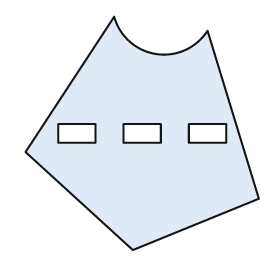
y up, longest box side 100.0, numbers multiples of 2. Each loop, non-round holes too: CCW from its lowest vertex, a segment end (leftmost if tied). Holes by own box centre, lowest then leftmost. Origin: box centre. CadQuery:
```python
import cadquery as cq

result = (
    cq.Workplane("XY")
    .moveTo(-4.0, -50.0)
    .lineTo(50.0, -28.0)
    .lineTo(28.0, 44.0)
    .threePointArc((6.0, 34.0), (-12.0, 50.0))
    .lineTo(-50.0, -8.0)
    .close()
    .moveTo(-36.0, -4.0)
    .lineTo(-20.0, -4.0)
    .lineTo(-20.0, 4.0)
    .lineTo(-36.0, 4.0)
    .close()
    .moveTo(-8.0, -4.0)
    .lineTo(8.0, -4.0)
    .lineTo(8.0, 4.0)
    .lineTo(-8.0, 4.0)
    .close()
    .moveTo(20.0, -4.0)
    .lineTo(36.0, -4.0)
    .lineTo(36.0, 4.0)
    .lineTo(20.0, 4.0)
    .close()
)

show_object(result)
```